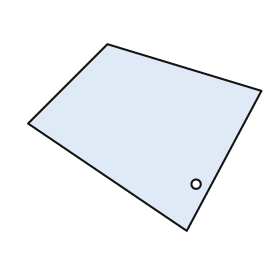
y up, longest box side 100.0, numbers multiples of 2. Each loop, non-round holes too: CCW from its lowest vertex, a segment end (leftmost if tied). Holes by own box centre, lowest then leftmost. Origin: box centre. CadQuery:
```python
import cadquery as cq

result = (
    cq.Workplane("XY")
    .moveTo(18.0, -40.0)
    .lineTo(50.0, 20.0)
    .lineTo(-16.0, 40.0)
    .lineTo(-50.0, 6.0)
    .close()
    .moveTo(22.0, -20.0)
    .circle(2.0)
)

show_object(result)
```